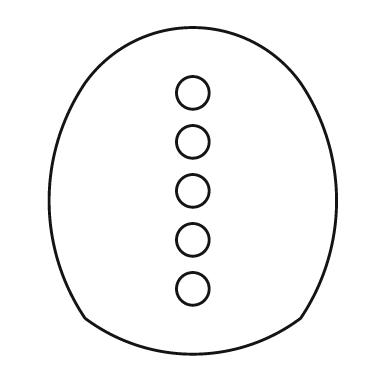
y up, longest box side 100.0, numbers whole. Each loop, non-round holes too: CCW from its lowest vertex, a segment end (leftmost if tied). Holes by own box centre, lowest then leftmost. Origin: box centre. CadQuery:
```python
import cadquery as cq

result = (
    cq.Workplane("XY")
    .moveTo(-33.0, -39.0)
    .threePointArc((0.0, -50.0), (33.0, -39.0))
    .threePointArc((44.0, -3.0), (33.0, 33.0))
    .threePointArc((0.0, 50.0), (-33.0, 33.0))
    .threePointArc((-44.0, -3.0), (-33.0, -39.0))
    .close()
    .moveTo(0.0, -30.0)
    .circle(5.0)
    .moveTo(0.0, -15.0)
    .circle(5.0)
    .moveTo(0.0, 0.0)
    .circle(5.0)
    .moveTo(0.0, 15.0)
    .circle(5.0)
    .moveTo(0.0, 30.0)
    .circle(5.0)
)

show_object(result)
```